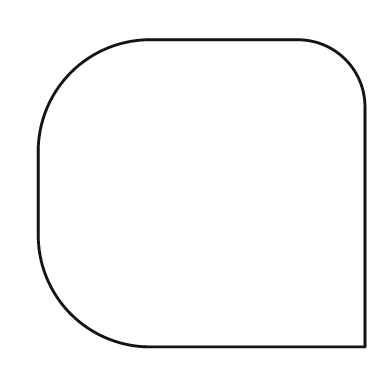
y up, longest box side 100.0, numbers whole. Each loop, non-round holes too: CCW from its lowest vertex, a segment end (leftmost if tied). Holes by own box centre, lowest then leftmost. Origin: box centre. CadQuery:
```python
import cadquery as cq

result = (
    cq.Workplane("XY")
    .moveTo(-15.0, -47.0)
    .lineTo(50.0, -47.0)
    .lineTo(50.0, 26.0)
    .threePointArc((44.0, 41.0), (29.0, 47.0))
    .lineTo(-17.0, 47.0)
    .threePointArc((-40.0, 37.0), (-50.0, 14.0))
    .lineTo(-50.0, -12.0)
    .threePointArc((-40.0, -37.0), (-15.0, -47.0))
    .close()
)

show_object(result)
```